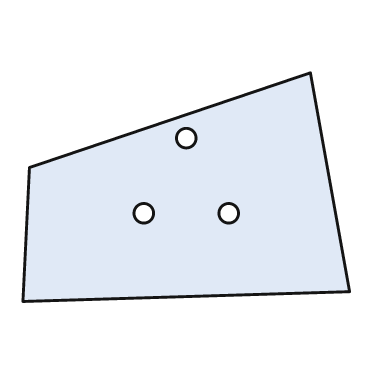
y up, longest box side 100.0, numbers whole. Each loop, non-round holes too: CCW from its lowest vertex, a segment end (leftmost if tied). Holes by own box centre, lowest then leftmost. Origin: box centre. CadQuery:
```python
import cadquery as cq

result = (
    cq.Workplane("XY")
    .moveTo(-50.0, -35.0)
    .lineTo(50.0, -32.0)
    .lineTo(38.0, 35.0)
    .lineTo(-48.0, 6.0)
    .close()
    .moveTo(-13.0, -8.0)
    .circle(3.0)
    .moveTo(13.0, -8.0)
    .circle(3.0)
    .moveTo(0.0, 15.0)
    .circle(3.0)
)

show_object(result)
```